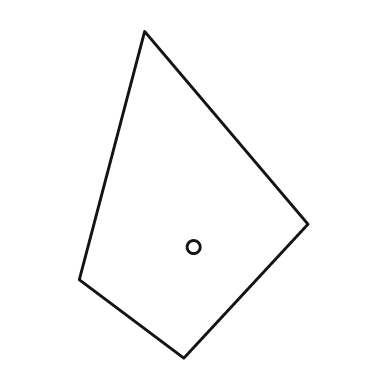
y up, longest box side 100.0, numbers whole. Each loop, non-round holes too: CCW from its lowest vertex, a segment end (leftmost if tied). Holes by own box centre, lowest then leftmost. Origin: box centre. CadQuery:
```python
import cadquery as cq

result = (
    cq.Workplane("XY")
    .moveTo(-3.0, -50.0)
    .lineTo(35.0, -9.0)
    .lineTo(-15.0, 50.0)
    .lineTo(-35.0, -26.0)
    .close()
    .moveTo(0.0, -16.0)
    .circle(2.0)
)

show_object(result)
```